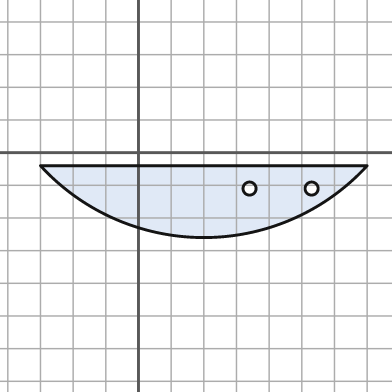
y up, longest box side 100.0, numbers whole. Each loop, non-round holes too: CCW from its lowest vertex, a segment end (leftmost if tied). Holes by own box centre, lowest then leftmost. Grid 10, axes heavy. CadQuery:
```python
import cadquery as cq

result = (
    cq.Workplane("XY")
    .moveTo(-30.0, -4.0)
    .threePointArc((20.0, -26.0), (70.0, -4.0))
    .close()
    .moveTo(34.0, -11.0)
    .circle(2.0)
    .moveTo(53.0, -11.0)
    .circle(2.0)
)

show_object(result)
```